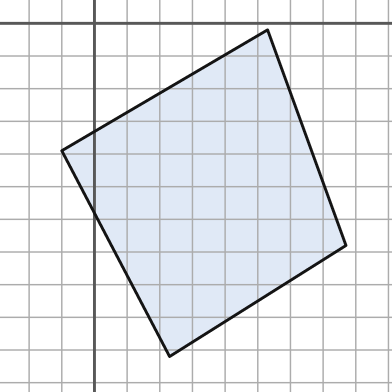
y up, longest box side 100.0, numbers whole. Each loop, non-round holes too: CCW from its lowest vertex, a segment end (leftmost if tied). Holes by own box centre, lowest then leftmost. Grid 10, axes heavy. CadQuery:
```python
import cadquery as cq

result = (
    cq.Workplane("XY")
    .moveTo(23.0, -102.0)
    .lineTo(77.0, -68.0)
    .lineTo(53.0, -2.0)
    .lineTo(-10.0, -39.0)
    .close()
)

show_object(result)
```